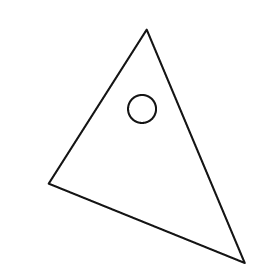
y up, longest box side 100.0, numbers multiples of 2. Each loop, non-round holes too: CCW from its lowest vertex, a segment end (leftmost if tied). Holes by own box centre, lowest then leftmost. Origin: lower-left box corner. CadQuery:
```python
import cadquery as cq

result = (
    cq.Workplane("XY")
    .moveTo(84.0, 0.0)
    .lineTo(42.0, 100.0)
    .lineTo(0.0, 34.0)
    .close()
    .moveTo(40.0, 66.0)
    .circle(6.0)
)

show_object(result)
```